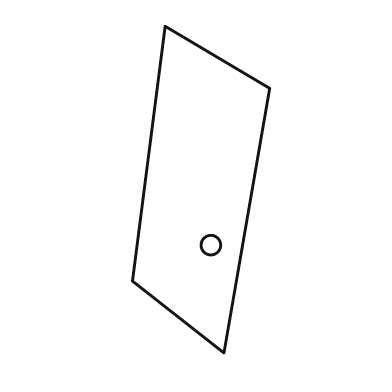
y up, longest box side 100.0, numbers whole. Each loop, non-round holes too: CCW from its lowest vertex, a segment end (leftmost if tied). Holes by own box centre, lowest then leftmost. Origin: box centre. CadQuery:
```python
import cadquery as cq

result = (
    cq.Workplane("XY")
    .moveTo(7.0, -50.0)
    .lineTo(21.0, 31.0)
    .lineTo(-11.0, 50.0)
    .lineTo(-21.0, -28.0)
    .close()
    .moveTo(3.0, -17.0)
    .circle(3.0)
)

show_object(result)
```